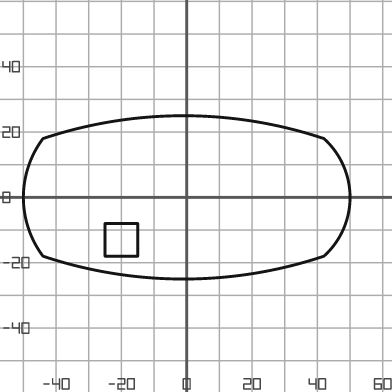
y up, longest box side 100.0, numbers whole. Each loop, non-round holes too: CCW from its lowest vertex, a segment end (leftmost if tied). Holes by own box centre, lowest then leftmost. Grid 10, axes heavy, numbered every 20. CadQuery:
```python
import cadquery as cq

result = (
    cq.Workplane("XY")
    .moveTo(-44.0, -18.0)
    .threePointArc((-1.0, -25.0), (42.0, -18.0))
    .threePointArc((50.0, 0.0), (42.0, 18.0))
    .threePointArc((-1.0, 25.0), (-44.0, 18.0))
    .threePointArc((-50.0, 0.0), (-44.0, -18.0))
    .close()
    .moveTo(-25.0, -18.0)
    .lineTo(-15.0, -18.0)
    .lineTo(-15.0, -8.0)
    .lineTo(-25.0, -8.0)
    .close()
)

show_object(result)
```